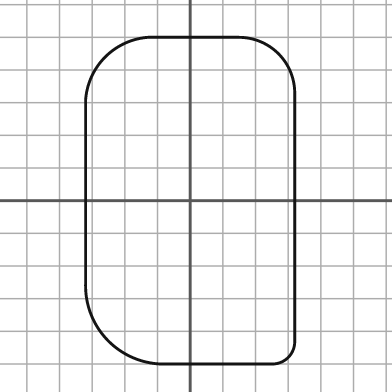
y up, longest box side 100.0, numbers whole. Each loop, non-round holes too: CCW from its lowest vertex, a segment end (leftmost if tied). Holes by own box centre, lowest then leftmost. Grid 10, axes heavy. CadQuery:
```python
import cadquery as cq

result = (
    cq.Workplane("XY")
    .moveTo(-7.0, -50.0)
    .lineTo(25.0, -50.0)
    .threePointArc((30.0, -48.0), (32.0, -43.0))
    .lineTo(32.0, 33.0)
    .threePointArc((27.0, 45.0), (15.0, 50.0))
    .lineTo(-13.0, 50.0)
    .threePointArc((-26.0, 44.0), (-32.0, 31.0))
    .lineTo(-32.0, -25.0)
    .threePointArc((-25.0, -43.0), (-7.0, -50.0))
    .close()
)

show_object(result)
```